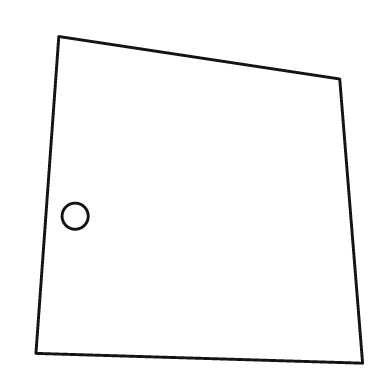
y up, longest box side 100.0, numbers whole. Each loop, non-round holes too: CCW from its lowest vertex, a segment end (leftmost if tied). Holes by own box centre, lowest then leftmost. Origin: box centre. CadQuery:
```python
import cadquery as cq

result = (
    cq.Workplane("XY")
    .moveTo(50.0, -50.0)
    .lineTo(43.0, 37.0)
    .lineTo(-43.0, 50.0)
    .lineTo(-50.0, -47.0)
    .close()
    .moveTo(-38.0, -5.0)
    .circle(4.0)
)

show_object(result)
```